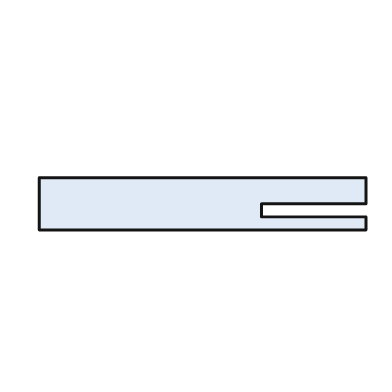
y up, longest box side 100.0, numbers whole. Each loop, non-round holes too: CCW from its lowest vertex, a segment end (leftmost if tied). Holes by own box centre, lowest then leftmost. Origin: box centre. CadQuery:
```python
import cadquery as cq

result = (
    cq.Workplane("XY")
    .moveTo(-50.0, -8.0)
    .lineTo(50.0, -8.0)
    .lineTo(50.0, -4.0)
    .lineTo(18.0, -4.0)
    .lineTo(18.0, 0.0)
    .lineTo(50.0, 0.0)
    .lineTo(50.0, 8.0)
    .lineTo(-50.0, 8.0)
    .close()
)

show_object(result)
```